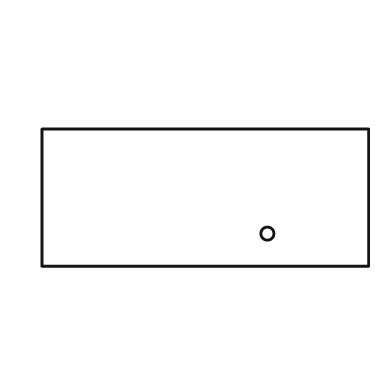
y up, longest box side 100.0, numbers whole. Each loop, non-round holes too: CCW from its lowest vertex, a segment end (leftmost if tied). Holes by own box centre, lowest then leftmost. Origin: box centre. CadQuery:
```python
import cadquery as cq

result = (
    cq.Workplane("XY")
    .moveTo(-50.0, -21.0)
    .lineTo(50.0, -21.0)
    .lineTo(50.0, 21.0)
    .lineTo(-50.0, 21.0)
    .close()
    .moveTo(19.0, -11.0)
    .circle(2.0)
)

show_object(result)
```